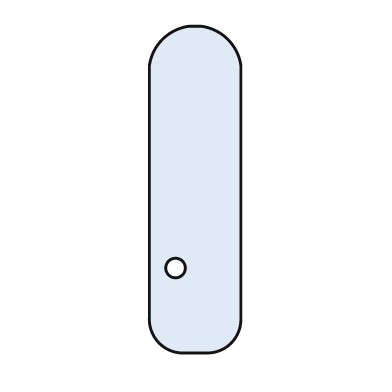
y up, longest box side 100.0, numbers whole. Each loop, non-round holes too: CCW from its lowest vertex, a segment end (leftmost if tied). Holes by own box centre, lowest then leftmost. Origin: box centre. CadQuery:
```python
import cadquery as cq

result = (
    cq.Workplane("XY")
    .moveTo(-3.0, -50.0)
    .lineTo(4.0, -50.0)
    .threePointArc((11.0, -47.0), (14.0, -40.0))
    .lineTo(14.0, 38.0)
    .threePointArc((10.0, 46.0), (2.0, 50.0))
    .lineTo(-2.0, 50.0)
    .threePointArc((-10.0, 46.0), (-14.0, 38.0))
    .lineTo(-14.0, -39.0)
    .threePointArc((-11.0, -47.0), (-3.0, -50.0))
    .close()
    .moveTo(-6.0, -24.0)
    .circle(3.0)
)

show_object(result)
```